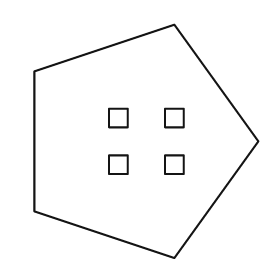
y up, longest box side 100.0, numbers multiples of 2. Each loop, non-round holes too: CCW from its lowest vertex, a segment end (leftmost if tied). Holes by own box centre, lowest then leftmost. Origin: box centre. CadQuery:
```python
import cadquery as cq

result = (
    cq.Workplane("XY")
    .moveTo(12.0, -50.0)
    .lineTo(48.0, 0.0)
    .lineTo(12.0, 50.0)
    .lineTo(-48.0, 30.0)
    .lineTo(-48.0, -30.0)
    .close()
    .moveTo(-16.0, -14.0)
    .lineTo(-8.0, -14.0)
    .lineTo(-8.0, -6.0)
    .lineTo(-16.0, -6.0)
    .close()
    .moveTo(8.0, -14.0)
    .lineTo(16.0, -14.0)
    .lineTo(16.0, -6.0)
    .lineTo(8.0, -6.0)
    .close()
    .moveTo(-16.0, 6.0)
    .lineTo(-8.0, 6.0)
    .lineTo(-8.0, 14.0)
    .lineTo(-16.0, 14.0)
    .close()
    .moveTo(8.0, 6.0)
    .lineTo(16.0, 6.0)
    .lineTo(16.0, 14.0)
    .lineTo(8.0, 14.0)
    .close()
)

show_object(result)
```